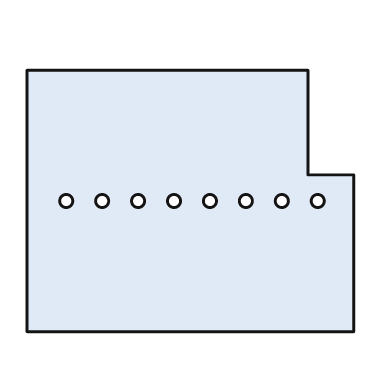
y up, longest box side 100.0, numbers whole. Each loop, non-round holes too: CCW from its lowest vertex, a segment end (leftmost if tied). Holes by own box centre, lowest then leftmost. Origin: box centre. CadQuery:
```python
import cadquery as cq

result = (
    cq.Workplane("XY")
    .moveTo(-50.0, -40.0)
    .lineTo(50.0, -40.0)
    .lineTo(50.0, 8.0)
    .lineTo(36.0, 8.0)
    .lineTo(36.0, 40.0)
    .lineTo(-50.0, 40.0)
    .close()
    .moveTo(-38.0, 0.0)
    .circle(2.0)
    .moveTo(-27.0, 0.0)
    .circle(2.0)
    .moveTo(-16.0, 0.0)
    .circle(2.0)
    .moveTo(-5.0, 0.0)
    .circle(2.0)
    .moveTo(6.0, 0.0)
    .circle(2.0)
    .moveTo(17.0, 0.0)
    .circle(2.0)
    .moveTo(28.0, 0.0)
    .circle(2.0)
    .moveTo(39.0, 0.0)
    .circle(2.0)
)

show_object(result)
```